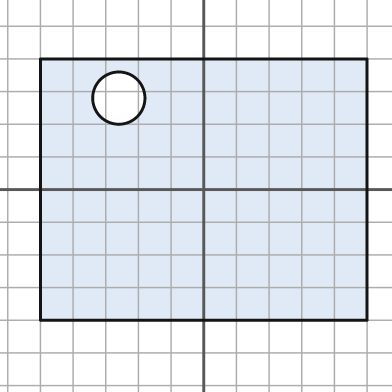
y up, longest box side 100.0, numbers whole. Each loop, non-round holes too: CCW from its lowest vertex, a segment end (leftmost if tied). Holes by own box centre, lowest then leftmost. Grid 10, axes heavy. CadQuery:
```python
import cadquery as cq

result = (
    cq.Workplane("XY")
    .moveTo(-50.0, -40.0)
    .lineTo(50.0, -40.0)
    .lineTo(50.0, 40.0)
    .lineTo(-50.0, 40.0)
    .close()
    .moveTo(-26.0, 28.0)
    .circle(8.0)
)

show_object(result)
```